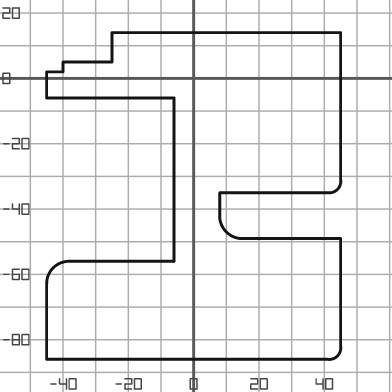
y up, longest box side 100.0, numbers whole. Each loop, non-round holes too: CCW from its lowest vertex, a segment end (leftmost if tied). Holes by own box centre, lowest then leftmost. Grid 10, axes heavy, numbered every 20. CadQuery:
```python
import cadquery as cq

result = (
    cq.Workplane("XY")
    .moveTo(-45.0, -86.0)
    .lineTo(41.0, -86.0)
    .threePointArc((44.0, -85.0), (45.0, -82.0))
    .lineTo(45.0, -49.0)
    .lineTo(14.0, -49.0)
    .threePointArc((10.0, -47.0), (8.0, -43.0))
    .lineTo(8.0, -35.0)
    .lineTo(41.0, -35.0)
    .threePointArc((44.0, -34.0), (45.0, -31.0))
    .lineTo(45.0, 14.0)
    .lineTo(-25.0, 14.0)
    .lineTo(-25.0, 5.0)
    .lineTo(-40.0, 5.0)
    .lineTo(-40.0, 2.0)
    .lineTo(-45.0, 2.0)
    .lineTo(-45.0, -6.0)
    .lineTo(-6.0, -6.0)
    .lineTo(-6.0, -56.0)
    .lineTo(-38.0, -56.0)
    .threePointArc((-43.0, -58.0), (-45.0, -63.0))
    .close()
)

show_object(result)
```